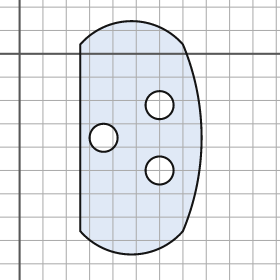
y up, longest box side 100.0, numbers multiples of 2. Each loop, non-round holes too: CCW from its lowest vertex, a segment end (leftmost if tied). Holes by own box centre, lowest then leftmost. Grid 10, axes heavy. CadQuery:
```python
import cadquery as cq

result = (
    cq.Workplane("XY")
    .moveTo(26.0, -76.0)
    .threePointArc((48.0, -86.0), (70.0, -76.0))
    .threePointArc((78.0, -36.0), (70.0, 4.0))
    .threePointArc((48.0, 14.0), (26.0, 4.0))
    .close()
    .moveTo(60.0, -50.0)
    .circle(6.0)
    .moveTo(36.0, -36.0)
    .circle(6.0)
    .moveTo(60.0, -22.0)
    .circle(6.0)
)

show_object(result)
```